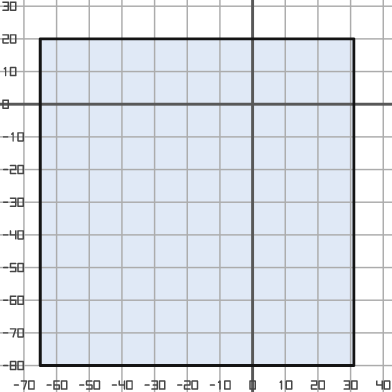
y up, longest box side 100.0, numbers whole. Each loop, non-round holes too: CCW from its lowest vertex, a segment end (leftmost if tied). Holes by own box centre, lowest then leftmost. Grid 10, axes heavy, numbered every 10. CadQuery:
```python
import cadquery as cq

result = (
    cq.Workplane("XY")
    .moveTo(-65.0, -80.0)
    .lineTo(31.0, -80.0)
    .lineTo(31.0, 20.0)
    .lineTo(-65.0, 20.0)
    .close()
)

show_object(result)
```